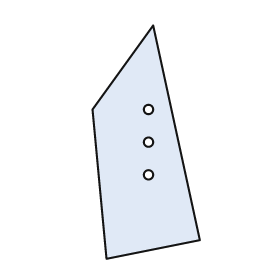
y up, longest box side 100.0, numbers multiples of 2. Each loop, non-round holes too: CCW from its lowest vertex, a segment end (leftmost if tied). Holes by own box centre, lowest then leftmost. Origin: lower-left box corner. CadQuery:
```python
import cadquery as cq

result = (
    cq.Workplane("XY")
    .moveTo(6.0, 0.0)
    .lineTo(46.0, 8.0)
    .lineTo(26.0, 100.0)
    .lineTo(0.0, 64.0)
    .close()
    .moveTo(24.0, 36.0)
    .circle(2.0)
    .moveTo(24.0, 50.0)
    .circle(2.0)
    .moveTo(24.0, 64.0)
    .circle(2.0)
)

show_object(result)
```